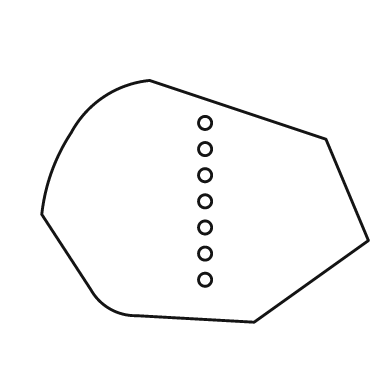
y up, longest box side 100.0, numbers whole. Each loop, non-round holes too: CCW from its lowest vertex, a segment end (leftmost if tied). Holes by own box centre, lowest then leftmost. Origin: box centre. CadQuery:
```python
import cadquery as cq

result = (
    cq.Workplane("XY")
    .moveTo(15.0, -37.0)
    .lineTo(50.0, -12.0)
    .lineTo(37.0, 19.0)
    .lineTo(-17.0, 37.0)
    .threePointArc((-31.0, 32.0), (-41.0, 21.0))
    .threePointArc((-47.0, 9.0), (-50.0, -4.0))
    .lineTo(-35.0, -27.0)
    .threePointArc((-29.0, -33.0), (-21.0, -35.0))
    .close()
    .moveTo(0.0, -24.0)
    .circle(2.0)
    .moveTo(0.0, -16.0)
    .circle(2.0)
    .moveTo(0.0, -8.0)
    .circle(2.0)
    .moveTo(0.0, 0.0)
    .circle(2.0)
    .moveTo(0.0, 8.0)
    .circle(2.0)
    .moveTo(0.0, 16.0)
    .circle(2.0)
    .moveTo(0.0, 24.0)
    .circle(2.0)
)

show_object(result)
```